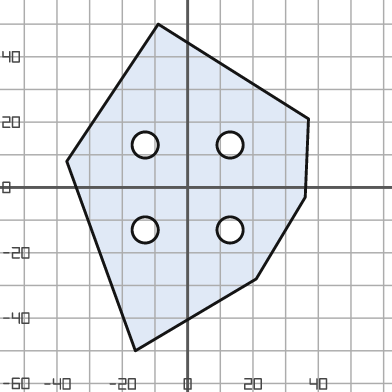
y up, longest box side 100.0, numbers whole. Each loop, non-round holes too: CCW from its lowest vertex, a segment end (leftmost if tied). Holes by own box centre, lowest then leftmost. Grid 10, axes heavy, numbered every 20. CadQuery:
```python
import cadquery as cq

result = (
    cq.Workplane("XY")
    .moveTo(-16.0, -50.0)
    .lineTo(21.0, -28.0)
    .lineTo(36.0, -3.0)
    .lineTo(37.0, 21.0)
    .lineTo(-9.0, 50.0)
    .lineTo(-37.0, 8.0)
    .close()
    .moveTo(-13.0, -13.0)
    .circle(4.0)
    .moveTo(13.0, -13.0)
    .circle(4.0)
    .moveTo(-13.0, 13.0)
    .circle(4.0)
    .moveTo(13.0, 13.0)
    .circle(4.0)
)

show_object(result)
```